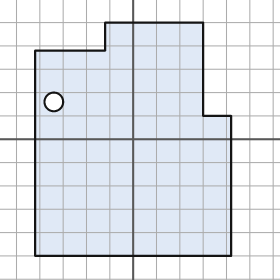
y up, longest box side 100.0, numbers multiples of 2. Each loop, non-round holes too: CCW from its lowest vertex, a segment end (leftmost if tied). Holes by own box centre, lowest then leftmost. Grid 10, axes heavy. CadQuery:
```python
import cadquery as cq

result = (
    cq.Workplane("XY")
    .moveTo(-42.0, -50.0)
    .lineTo(42.0, -50.0)
    .lineTo(42.0, 10.0)
    .lineTo(30.0, 10.0)
    .lineTo(30.0, 50.0)
    .lineTo(-12.0, 50.0)
    .lineTo(-12.0, 38.0)
    .lineTo(-42.0, 38.0)
    .close()
    .moveTo(-34.0, 16.0)
    .circle(4.0)
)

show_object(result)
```